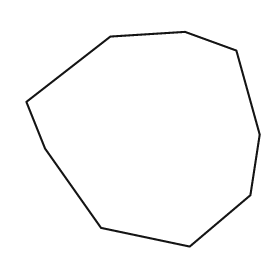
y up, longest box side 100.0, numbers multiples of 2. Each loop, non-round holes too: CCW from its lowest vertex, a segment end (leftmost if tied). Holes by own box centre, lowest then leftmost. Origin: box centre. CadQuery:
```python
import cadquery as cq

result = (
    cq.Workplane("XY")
    .moveTo(20.0, -46.0)
    .lineTo(46.0, -24.0)
    .lineTo(50.0, 2.0)
    .lineTo(40.0, 38.0)
    .lineTo(18.0, 46.0)
    .lineTo(-14.0, 44.0)
    .lineTo(-50.0, 16.0)
    .lineTo(-42.0, -4.0)
    .lineTo(-18.0, -38.0)
    .close()
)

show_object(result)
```